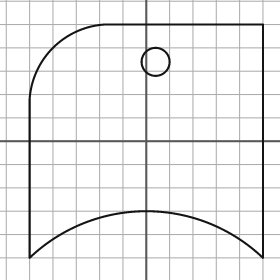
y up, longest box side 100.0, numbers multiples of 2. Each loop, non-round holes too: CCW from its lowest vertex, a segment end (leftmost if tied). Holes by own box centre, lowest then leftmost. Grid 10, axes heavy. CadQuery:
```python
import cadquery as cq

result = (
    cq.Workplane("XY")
    .moveTo(-50.0, -50.0)
    .threePointArc((0.0, -30.0), (50.0, -50.0))
    .lineTo(50.0, 50.0)
    .lineTo(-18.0, 50.0)
    .threePointArc((-40.0, 40.0), (-50.0, 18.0))
    .close()
    .moveTo(4.0, 34.0)
    .circle(6.0)
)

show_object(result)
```